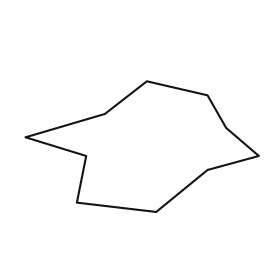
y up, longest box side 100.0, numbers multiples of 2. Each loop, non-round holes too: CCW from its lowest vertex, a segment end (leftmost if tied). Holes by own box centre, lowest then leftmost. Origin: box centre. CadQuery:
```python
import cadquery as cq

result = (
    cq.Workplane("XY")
    .moveTo(6.0, -28.0)
    .lineTo(28.0, -10.0)
    .lineTo(50.0, -4.0)
    .lineTo(36.0, 8.0)
    .lineTo(28.0, 22.0)
    .lineTo(2.0, 28.0)
    .lineTo(-16.0, 14.0)
    .lineTo(-50.0, 4.0)
    .lineTo(-24.0, -4.0)
    .lineTo(-28.0, -24.0)
    .close()
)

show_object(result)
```